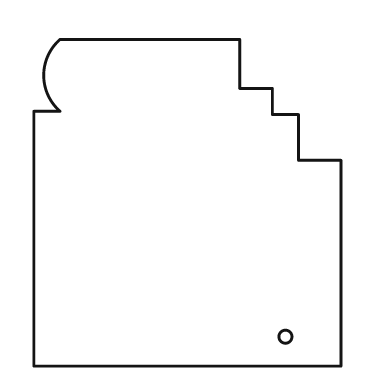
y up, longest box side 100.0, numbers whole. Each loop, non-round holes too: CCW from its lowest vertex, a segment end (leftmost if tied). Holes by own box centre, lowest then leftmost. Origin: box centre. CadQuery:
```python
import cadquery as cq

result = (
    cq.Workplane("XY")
    .moveTo(-47.0, -50.0)
    .lineTo(47.0, -50.0)
    .lineTo(47.0, 13.0)
    .lineTo(34.0, 13.0)
    .lineTo(34.0, 27.0)
    .lineTo(26.0, 27.0)
    .lineTo(26.0, 35.0)
    .lineTo(16.0, 35.0)
    .lineTo(16.0, 50.0)
    .lineTo(-39.0, 50.0)
    .threePointArc((-44.0, 39.0), (-39.0, 28.0))
    .lineTo(-47.0, 28.0)
    .close()
    .moveTo(30.0, -41.0)
    .circle(2.0)
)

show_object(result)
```